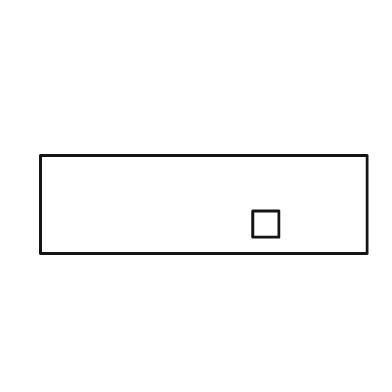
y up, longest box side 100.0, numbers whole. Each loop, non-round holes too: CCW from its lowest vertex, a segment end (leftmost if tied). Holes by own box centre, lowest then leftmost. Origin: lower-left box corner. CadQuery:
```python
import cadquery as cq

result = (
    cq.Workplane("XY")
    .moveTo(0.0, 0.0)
    .lineTo(100.0, 0.0)
    .lineTo(100.0, 30.0)
    .lineTo(0.0, 30.0)
    .close()
    .moveTo(65.0, 5.0)
    .lineTo(73.0, 5.0)
    .lineTo(73.0, 13.0)
    .lineTo(65.0, 13.0)
    .close()
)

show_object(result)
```